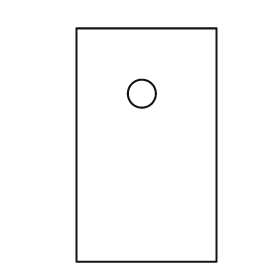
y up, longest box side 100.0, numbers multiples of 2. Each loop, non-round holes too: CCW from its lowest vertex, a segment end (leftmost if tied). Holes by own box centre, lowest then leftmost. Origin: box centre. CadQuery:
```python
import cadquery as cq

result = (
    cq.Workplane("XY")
    .moveTo(-30.0, -50.0)
    .lineTo(30.0, -50.0)
    .lineTo(30.0, 50.0)
    .lineTo(-30.0, 50.0)
    .close()
    .moveTo(-2.0, 22.0)
    .circle(6.0)
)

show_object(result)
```